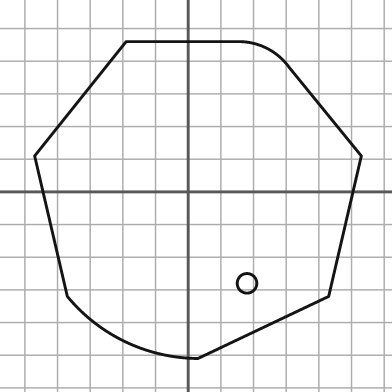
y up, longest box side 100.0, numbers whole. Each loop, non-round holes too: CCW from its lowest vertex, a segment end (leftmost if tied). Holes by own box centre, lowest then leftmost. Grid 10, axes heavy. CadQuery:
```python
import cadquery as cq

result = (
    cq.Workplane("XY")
    .moveTo(3.0, -51.0)
    .lineTo(43.0, -32.0)
    .lineTo(53.0, 11.0)
    .lineTo(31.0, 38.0)
    .threePointArc((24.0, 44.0), (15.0, 46.0))
    .lineTo(-19.0, 46.0)
    .lineTo(-47.0, 11.0)
    .lineTo(-37.0, -32.0)
    .threePointArc((-19.0, -46.0), (3.0, -51.0))
    .close()
    .moveTo(18.0, -28.0)
    .circle(3.0)
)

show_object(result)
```